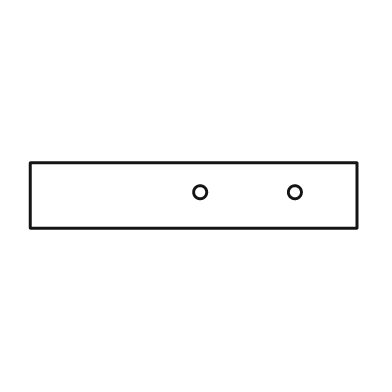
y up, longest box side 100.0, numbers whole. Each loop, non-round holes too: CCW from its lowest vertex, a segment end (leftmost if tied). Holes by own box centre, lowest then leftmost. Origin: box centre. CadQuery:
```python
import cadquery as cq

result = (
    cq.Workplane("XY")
    .moveTo(-50.0, -10.0)
    .lineTo(50.0, -10.0)
    .lineTo(50.0, 10.0)
    .lineTo(-50.0, 10.0)
    .close()
    .moveTo(2.0, 1.0)
    .circle(2.0)
    .moveTo(31.0, 1.0)
    .circle(2.0)
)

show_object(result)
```